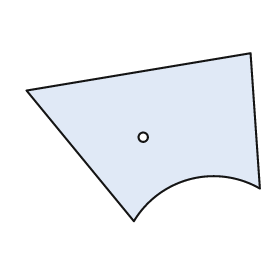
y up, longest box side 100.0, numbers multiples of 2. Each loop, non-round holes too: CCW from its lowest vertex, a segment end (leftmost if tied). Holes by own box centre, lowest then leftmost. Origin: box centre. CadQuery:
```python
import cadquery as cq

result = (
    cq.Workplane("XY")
    .moveTo(-4.0, -36.0)
    .threePointArc((20.0, -18.0), (50.0, -22.0))
    .lineTo(46.0, 36.0)
    .lineTo(-50.0, 20.0)
    .close()
    .moveTo(0.0, 0.0)
    .circle(2.0)
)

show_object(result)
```